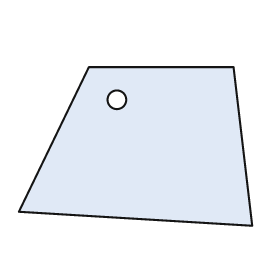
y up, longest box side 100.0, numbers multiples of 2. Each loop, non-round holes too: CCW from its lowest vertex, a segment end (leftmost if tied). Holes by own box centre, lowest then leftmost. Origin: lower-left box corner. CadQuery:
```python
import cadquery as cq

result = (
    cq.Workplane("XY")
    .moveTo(100.0, 0.0)
    .lineTo(92.0, 68.0)
    .lineTo(30.0, 68.0)
    .lineTo(0.0, 6.0)
    .close()
    .moveTo(42.0, 54.0)
    .circle(4.0)
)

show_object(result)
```